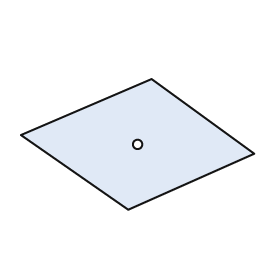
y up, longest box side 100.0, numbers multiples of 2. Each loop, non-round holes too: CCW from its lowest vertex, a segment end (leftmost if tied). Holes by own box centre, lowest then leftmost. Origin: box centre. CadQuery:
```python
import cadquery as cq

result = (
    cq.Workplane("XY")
    .moveTo(-4.0, -28.0)
    .lineTo(50.0, -4.0)
    .lineTo(6.0, 28.0)
    .lineTo(-50.0, 4.0)
    .close()
    .moveTo(0.0, 0.0)
    .circle(2.0)
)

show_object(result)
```